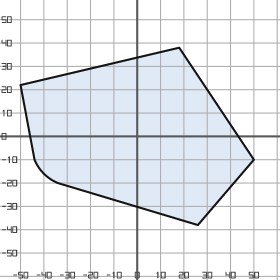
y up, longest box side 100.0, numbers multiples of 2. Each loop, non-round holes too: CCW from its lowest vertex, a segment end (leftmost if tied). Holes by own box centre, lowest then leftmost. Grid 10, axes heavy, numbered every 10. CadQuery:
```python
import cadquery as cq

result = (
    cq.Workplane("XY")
    .moveTo(26.0, -38.0)
    .lineTo(50.0, -10.0)
    .lineTo(18.0, 38.0)
    .lineTo(-50.0, 22.0)
    .lineTo(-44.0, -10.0)
    .threePointArc((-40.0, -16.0), (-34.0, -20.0))
    .close()
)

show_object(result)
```